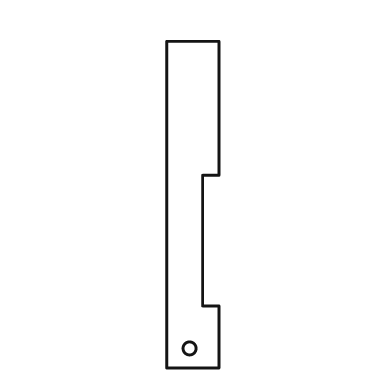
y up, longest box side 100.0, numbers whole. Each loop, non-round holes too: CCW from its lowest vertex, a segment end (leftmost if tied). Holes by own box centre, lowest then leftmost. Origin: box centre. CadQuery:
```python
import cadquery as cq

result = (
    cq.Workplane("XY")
    .moveTo(-8.0, -50.0)
    .lineTo(8.0, -50.0)
    .lineTo(8.0, -31.0)
    .lineTo(3.0, -31.0)
    .lineTo(3.0, 9.0)
    .lineTo(8.0, 9.0)
    .lineTo(8.0, 50.0)
    .lineTo(-8.0, 50.0)
    .close()
    .moveTo(-1.0, -44.0)
    .circle(2.0)
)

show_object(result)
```